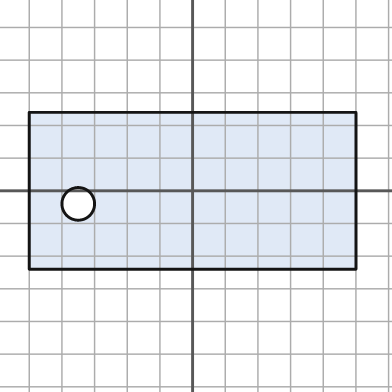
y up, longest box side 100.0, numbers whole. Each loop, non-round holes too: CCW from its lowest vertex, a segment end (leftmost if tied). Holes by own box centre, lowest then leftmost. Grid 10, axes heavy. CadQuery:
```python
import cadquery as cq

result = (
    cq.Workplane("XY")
    .moveTo(-50.0, -24.0)
    .lineTo(50.0, -24.0)
    .lineTo(50.0, 24.0)
    .lineTo(-50.0, 24.0)
    .close()
    .moveTo(-35.0, -4.0)
    .circle(5.0)
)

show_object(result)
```